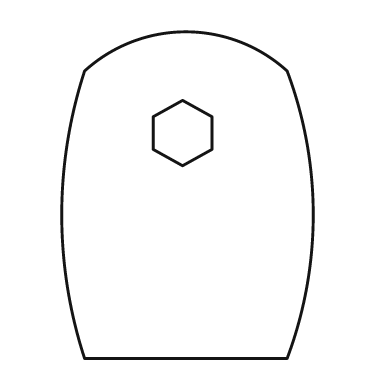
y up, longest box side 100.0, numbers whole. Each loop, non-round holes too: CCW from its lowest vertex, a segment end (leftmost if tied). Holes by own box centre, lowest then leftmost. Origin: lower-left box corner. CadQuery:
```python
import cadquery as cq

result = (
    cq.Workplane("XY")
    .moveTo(7.0, 0.0)
    .lineTo(69.0, 0.0)
    .threePointArc((77.0, 44.0), (69.0, 88.0))
    .threePointArc((38.0, 100.0), (7.0, 88.0))
    .threePointArc((0.0, 44.0), (7.0, 0.0))
    .close()
    .moveTo(37.0, 59.0)
    .lineTo(46.0, 64.0)
    .lineTo(46.0, 74.0)
    .lineTo(37.0, 79.0)
    .lineTo(28.0, 74.0)
    .lineTo(28.0, 64.0)
    .close()
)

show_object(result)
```